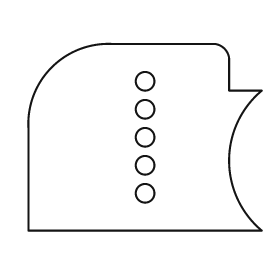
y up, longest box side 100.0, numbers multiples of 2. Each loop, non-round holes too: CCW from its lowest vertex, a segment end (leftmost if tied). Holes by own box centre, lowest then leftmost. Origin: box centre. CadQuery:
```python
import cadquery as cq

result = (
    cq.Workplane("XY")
    .moveTo(-50.0, -40.0)
    .lineTo(50.0, -40.0)
    .threePointArc((36.0, -10.0), (50.0, 20.0))
    .lineTo(36.0, 20.0)
    .lineTo(36.0, 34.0)
    .threePointArc((34.0, 38.0), (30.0, 40.0))
    .lineTo(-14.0, 40.0)
    .threePointArc((-40.0, 30.0), (-50.0, 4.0))
    .close()
    .moveTo(0.0, -24.0)
    .circle(4.0)
    .moveTo(0.0, -12.0)
    .circle(4.0)
    .moveTo(0.0, 0.0)
    .circle(4.0)
    .moveTo(0.0, 12.0)
    .circle(4.0)
    .moveTo(0.0, 24.0)
    .circle(4.0)
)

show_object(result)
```